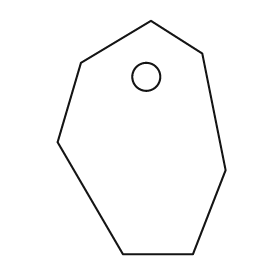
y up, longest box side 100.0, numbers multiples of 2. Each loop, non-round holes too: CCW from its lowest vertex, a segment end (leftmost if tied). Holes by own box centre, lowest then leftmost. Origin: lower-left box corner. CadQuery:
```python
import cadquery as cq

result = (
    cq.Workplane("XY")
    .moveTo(28.0, 0.0)
    .lineTo(58.0, 0.0)
    .lineTo(72.0, 36.0)
    .lineTo(62.0, 86.0)
    .lineTo(40.0, 100.0)
    .lineTo(10.0, 82.0)
    .lineTo(0.0, 48.0)
    .close()
    .moveTo(38.0, 76.0)
    .circle(6.0)
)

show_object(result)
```